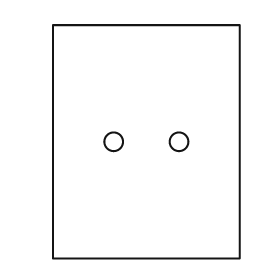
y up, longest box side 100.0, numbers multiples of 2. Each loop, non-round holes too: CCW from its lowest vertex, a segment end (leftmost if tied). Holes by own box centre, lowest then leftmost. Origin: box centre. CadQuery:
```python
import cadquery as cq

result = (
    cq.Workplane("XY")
    .moveTo(-40.0, -50.0)
    .lineTo(40.0, -50.0)
    .lineTo(40.0, 50.0)
    .lineTo(-40.0, 50.0)
    .close()
    .moveTo(-14.0, 0.0)
    .circle(4.0)
    .moveTo(14.0, 0.0)
    .circle(4.0)
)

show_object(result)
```